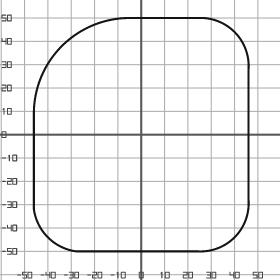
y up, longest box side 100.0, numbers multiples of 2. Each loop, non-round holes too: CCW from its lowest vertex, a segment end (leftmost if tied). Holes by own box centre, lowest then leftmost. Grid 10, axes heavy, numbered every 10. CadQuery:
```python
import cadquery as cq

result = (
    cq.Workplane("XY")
    .moveTo(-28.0, -50.0)
    .lineTo(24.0, -50.0)
    .threePointArc((40.0, -44.0), (46.0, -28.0))
    .lineTo(46.0, 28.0)
    .threePointArc((40.0, 44.0), (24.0, 50.0))
    .lineTo(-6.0, 50.0)
    .threePointArc((-34.0, 38.0), (-46.0, 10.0))
    .lineTo(-46.0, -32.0)
    .threePointArc((-40.0, -44.0), (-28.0, -50.0))
    .close()
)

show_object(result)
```